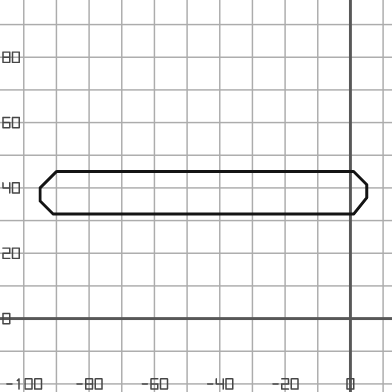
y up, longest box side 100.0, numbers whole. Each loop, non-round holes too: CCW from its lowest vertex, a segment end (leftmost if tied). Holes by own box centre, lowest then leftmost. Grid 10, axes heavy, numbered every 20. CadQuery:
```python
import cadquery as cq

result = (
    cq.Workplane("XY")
    .moveTo(-91.0, 32.0)
    .lineTo(1.0, 32.0)
    .lineTo(5.0, 37.0)
    .lineTo(5.0, 41.0)
    .lineTo(1.0, 45.0)
    .lineTo(-90.0, 45.0)
    .lineTo(-95.0, 40.0)
    .lineTo(-95.0, 36.0)
    .close()
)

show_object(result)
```